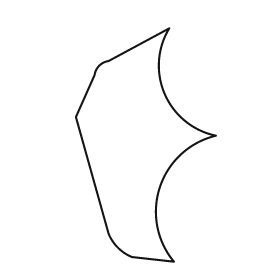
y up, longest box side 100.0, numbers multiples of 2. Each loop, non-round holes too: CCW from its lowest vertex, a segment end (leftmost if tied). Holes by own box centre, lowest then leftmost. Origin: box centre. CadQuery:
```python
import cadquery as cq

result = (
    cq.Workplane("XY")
    .moveTo(12.0, -50.0)
    .threePointArc((6.0, -18.0), (30.0, 4.0))
    .threePointArc((8.0, 22.0), (10.0, 50.0))
    .lineTo(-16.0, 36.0)
    .threePointArc((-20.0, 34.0), (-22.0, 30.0))
    .lineTo(-30.0, 12.0)
    .lineTo(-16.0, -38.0)
    .threePointArc((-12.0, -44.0), (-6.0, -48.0))
    .close()
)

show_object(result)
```